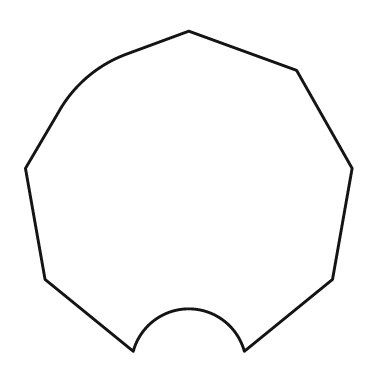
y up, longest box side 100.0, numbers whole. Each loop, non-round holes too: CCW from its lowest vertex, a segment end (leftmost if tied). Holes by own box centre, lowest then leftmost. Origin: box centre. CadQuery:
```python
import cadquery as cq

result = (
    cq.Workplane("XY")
    .moveTo(-17.0, -49.0)
    .threePointArc((0.0, -36.0), (17.0, -49.0))
    .lineTo(44.0, -27.0)
    .lineTo(50.0, 7.0)
    .lineTo(33.0, 37.0)
    .lineTo(0.0, 49.0)
    .lineTo(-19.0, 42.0)
    .threePointArc((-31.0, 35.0), (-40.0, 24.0))
    .lineTo(-50.0, 7.0)
    .lineTo(-44.0, -27.0)
    .close()
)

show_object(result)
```